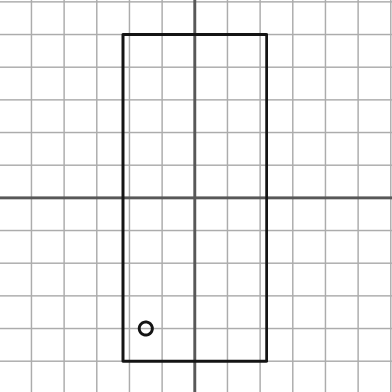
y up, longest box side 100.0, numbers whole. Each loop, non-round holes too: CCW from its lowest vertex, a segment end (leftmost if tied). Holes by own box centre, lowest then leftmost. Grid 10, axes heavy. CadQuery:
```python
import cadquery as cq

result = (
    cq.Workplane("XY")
    .moveTo(-22.0, -50.0)
    .lineTo(22.0, -50.0)
    .lineTo(22.0, 50.0)
    .lineTo(-22.0, 50.0)
    .close()
    .moveTo(-15.0, -40.0)
    .circle(2.0)
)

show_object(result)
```